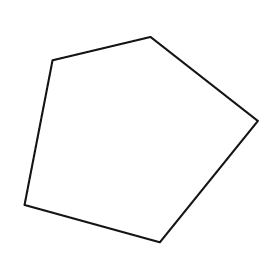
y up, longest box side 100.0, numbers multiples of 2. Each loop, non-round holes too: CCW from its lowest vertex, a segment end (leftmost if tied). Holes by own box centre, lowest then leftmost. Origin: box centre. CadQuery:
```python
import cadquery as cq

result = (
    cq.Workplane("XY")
    .moveTo(8.0, -44.0)
    .lineTo(50.0, 8.0)
    .lineTo(4.0, 44.0)
    .lineTo(-38.0, 34.0)
    .lineTo(-50.0, -28.0)
    .close()
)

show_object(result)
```